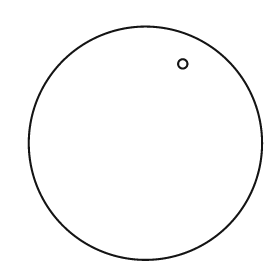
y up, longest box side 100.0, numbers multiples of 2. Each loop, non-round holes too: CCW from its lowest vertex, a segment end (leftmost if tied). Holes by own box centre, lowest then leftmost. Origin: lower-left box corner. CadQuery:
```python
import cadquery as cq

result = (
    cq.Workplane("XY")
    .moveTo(50.0, 50.0)
    .circle(50.0)
    .moveTo(66.0, 84.0)
    .circle(2.0)
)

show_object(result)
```